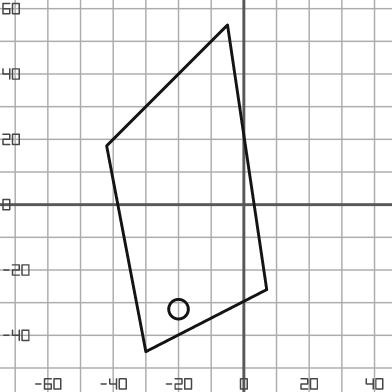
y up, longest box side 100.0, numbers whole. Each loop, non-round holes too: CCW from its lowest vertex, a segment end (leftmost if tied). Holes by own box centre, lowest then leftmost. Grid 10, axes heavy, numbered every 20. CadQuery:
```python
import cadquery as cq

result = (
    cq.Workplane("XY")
    .moveTo(-30.0, -45.0)
    .lineTo(7.0, -26.0)
    .lineTo(-5.0, 55.0)
    .lineTo(-42.0, 18.0)
    .close()
    .moveTo(-20.0, -32.0)
    .circle(3.0)
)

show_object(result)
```